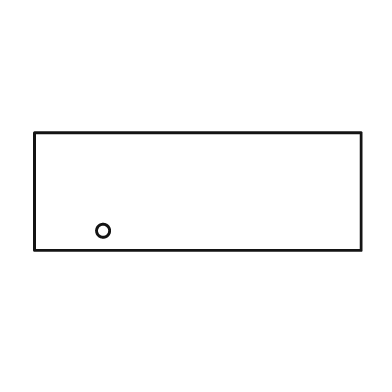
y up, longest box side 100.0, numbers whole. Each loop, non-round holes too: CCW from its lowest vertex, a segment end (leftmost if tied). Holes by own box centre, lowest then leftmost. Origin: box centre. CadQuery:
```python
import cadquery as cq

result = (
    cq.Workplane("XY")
    .moveTo(-50.0, -18.0)
    .lineTo(50.0, -18.0)
    .lineTo(50.0, 18.0)
    .lineTo(-50.0, 18.0)
    .close()
    .moveTo(-29.0, -12.0)
    .circle(2.0)
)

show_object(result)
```